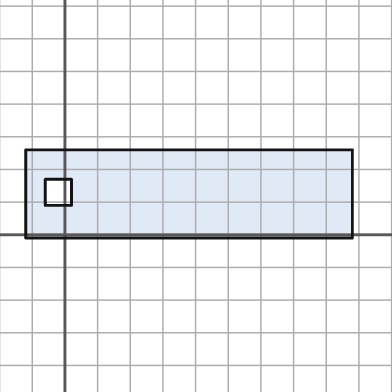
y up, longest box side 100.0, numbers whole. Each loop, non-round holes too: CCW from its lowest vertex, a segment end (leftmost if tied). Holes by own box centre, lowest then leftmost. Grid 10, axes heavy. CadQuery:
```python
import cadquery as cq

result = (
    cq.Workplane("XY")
    .moveTo(-12.0, -1.0)
    .lineTo(88.0, -1.0)
    .lineTo(88.0, 26.0)
    .lineTo(-12.0, 26.0)
    .close()
    .moveTo(-6.0, 9.0)
    .lineTo(2.0, 9.0)
    .lineTo(2.0, 17.0)
    .lineTo(-6.0, 17.0)
    .close()
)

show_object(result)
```